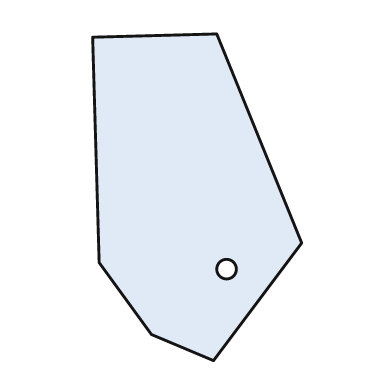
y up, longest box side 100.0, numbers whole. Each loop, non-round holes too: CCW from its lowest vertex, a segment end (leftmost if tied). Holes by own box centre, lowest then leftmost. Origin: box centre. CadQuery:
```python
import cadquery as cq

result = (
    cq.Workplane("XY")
    .moveTo(5.0, -50.0)
    .lineTo(32.0, -14.0)
    .lineTo(6.0, 50.0)
    .lineTo(-32.0, 49.0)
    .lineTo(-30.0, -20.0)
    .lineTo(-14.0, -42.0)
    .close()
    .moveTo(9.0, -22.0)
    .circle(3.0)
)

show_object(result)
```